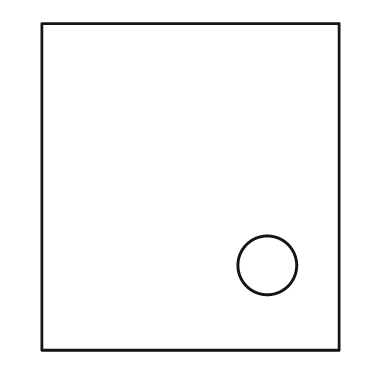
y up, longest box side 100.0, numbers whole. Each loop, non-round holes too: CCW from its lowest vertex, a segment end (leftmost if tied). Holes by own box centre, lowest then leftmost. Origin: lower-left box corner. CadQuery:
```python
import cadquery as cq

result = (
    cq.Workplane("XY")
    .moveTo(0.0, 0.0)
    .lineTo(91.0, 0.0)
    .lineTo(91.0, 100.0)
    .lineTo(0.0, 100.0)
    .close()
    .moveTo(69.0, 26.0)
    .circle(9.0)
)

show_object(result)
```